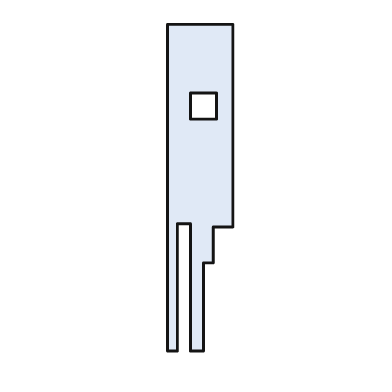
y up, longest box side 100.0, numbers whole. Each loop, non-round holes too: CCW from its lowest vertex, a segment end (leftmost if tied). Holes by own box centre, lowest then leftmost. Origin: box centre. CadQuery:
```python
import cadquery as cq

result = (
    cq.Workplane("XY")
    .moveTo(-10.0, -50.0)
    .lineTo(-7.0, -50.0)
    .lineTo(-7.0, -11.0)
    .lineTo(-3.0, -11.0)
    .lineTo(-3.0, -50.0)
    .lineTo(1.0, -50.0)
    .lineTo(1.0, -23.0)
    .lineTo(4.0, -23.0)
    .lineTo(4.0, -12.0)
    .lineTo(10.0, -12.0)
    .lineTo(10.0, 50.0)
    .lineTo(-10.0, 50.0)
    .close()
    .moveTo(-3.0, 21.0)
    .lineTo(5.0, 21.0)
    .lineTo(5.0, 29.0)
    .lineTo(-3.0, 29.0)
    .close()
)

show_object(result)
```